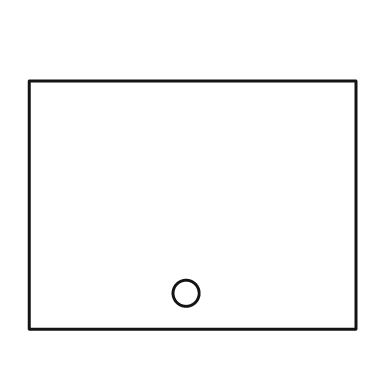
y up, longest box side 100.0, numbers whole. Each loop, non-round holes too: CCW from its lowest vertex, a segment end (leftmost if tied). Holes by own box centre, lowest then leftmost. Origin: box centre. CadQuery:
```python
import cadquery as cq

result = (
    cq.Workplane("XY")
    .moveTo(-50.0, -38.0)
    .lineTo(50.0, -38.0)
    .lineTo(50.0, 38.0)
    .lineTo(-50.0, 38.0)
    .close()
    .moveTo(-2.0, -27.0)
    .circle(4.0)
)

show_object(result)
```